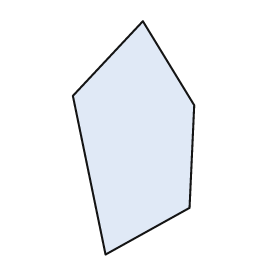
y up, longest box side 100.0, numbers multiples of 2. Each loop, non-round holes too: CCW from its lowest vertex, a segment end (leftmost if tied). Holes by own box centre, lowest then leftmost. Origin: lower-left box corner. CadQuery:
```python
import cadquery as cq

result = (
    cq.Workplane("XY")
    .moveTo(14.0, 0.0)
    .lineTo(50.0, 20.0)
    .lineTo(52.0, 64.0)
    .lineTo(30.0, 100.0)
    .lineTo(0.0, 68.0)
    .close()
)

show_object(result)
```